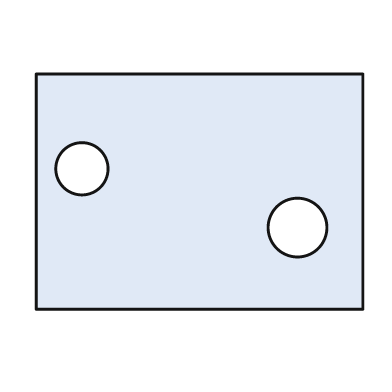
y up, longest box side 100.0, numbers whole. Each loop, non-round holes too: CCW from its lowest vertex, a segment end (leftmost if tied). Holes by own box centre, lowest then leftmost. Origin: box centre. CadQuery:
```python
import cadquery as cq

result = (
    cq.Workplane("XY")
    .moveTo(-50.0, -36.0)
    .lineTo(50.0, -36.0)
    .lineTo(50.0, 36.0)
    .lineTo(-50.0, 36.0)
    .close()
    .moveTo(30.0, -11.0)
    .circle(9.0)
    .moveTo(-36.0, 7.0)
    .circle(8.0)
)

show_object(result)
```